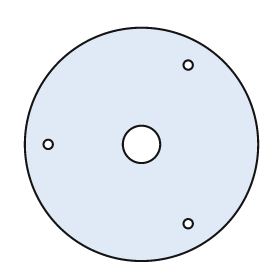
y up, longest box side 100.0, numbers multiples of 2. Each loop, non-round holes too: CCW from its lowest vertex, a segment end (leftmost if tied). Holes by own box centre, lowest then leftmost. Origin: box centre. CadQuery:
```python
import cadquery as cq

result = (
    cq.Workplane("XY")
    .moveTo(0.0, 0.0)
    .circle(50.0)
    .moveTo(20.0, -34.0)
    .circle(2.0)
    .moveTo(-40.0, 0.0)
    .circle(2.0)
    .moveTo(0.0, 0.0)
    .circle(8.0)
    .moveTo(20.0, 34.0)
    .circle(2.0)
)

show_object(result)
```